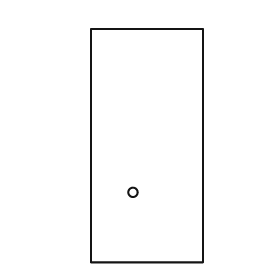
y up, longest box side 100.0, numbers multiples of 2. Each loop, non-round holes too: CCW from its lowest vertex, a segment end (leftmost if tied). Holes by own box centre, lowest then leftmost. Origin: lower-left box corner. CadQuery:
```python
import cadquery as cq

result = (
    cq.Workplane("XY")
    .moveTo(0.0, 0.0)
    .lineTo(48.0, 0.0)
    .lineTo(48.0, 100.0)
    .lineTo(0.0, 100.0)
    .close()
    .moveTo(18.0, 30.0)
    .circle(2.0)
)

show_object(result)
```